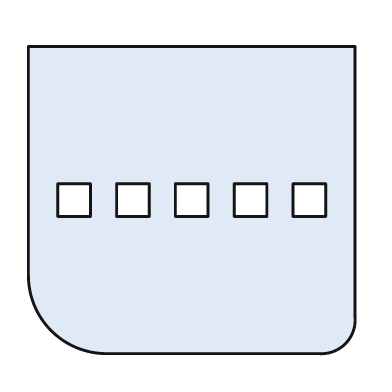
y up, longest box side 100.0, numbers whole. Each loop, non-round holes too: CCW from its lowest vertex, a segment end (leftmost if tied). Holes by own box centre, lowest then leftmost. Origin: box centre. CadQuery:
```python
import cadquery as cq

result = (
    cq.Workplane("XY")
    .moveTo(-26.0, -47.0)
    .lineTo(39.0, -47.0)
    .threePointArc((47.0, -44.0), (50.0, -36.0))
    .lineTo(50.0, 47.0)
    .lineTo(-50.0, 47.0)
    .lineTo(-50.0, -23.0)
    .threePointArc((-43.0, -40.0), (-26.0, -47.0))
    .close()
    .moveTo(-41.0, -5.0)
    .lineTo(-31.0, -5.0)
    .lineTo(-31.0, 5.0)
    .lineTo(-41.0, 5.0)
    .close()
    .moveTo(-23.0, -5.0)
    .lineTo(-13.0, -5.0)
    .lineTo(-13.0, 5.0)
    .lineTo(-23.0, 5.0)
    .close()
    .moveTo(-5.0, -5.0)
    .lineTo(5.0, -5.0)
    .lineTo(5.0, 5.0)
    .lineTo(-5.0, 5.0)
    .close()
    .moveTo(13.0, -5.0)
    .lineTo(23.0, -5.0)
    .lineTo(23.0, 5.0)
    .lineTo(13.0, 5.0)
    .close()
    .moveTo(31.0, -5.0)
    .lineTo(41.0, -5.0)
    .lineTo(41.0, 5.0)
    .lineTo(31.0, 5.0)
    .close()
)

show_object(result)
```